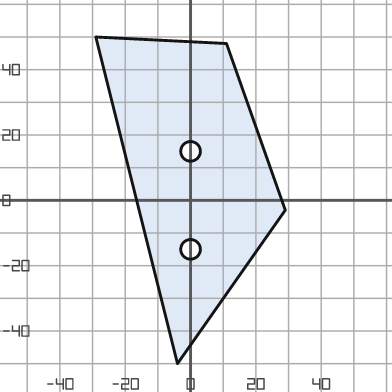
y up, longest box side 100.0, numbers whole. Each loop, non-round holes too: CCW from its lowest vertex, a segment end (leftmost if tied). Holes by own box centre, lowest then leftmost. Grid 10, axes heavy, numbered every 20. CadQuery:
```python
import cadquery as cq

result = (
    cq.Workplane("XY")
    .moveTo(-4.0, -50.0)
    .lineTo(29.0, -3.0)
    .lineTo(11.0, 48.0)
    .lineTo(-29.0, 50.0)
    .close()
    .moveTo(0.0, -15.0)
    .circle(3.0)
    .moveTo(0.0, 15.0)
    .circle(3.0)
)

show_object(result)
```